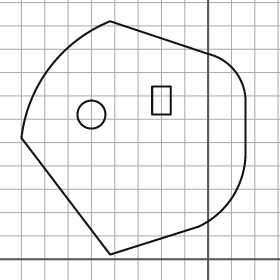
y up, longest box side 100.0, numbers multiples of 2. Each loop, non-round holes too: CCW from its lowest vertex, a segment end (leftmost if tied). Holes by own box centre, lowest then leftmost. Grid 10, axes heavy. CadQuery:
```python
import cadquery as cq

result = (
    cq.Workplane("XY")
    .moveTo(-42.0, 2.0)
    .lineTo(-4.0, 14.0)
    .threePointArc((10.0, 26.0), (16.0, 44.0))
    .lineTo(16.0, 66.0)
    .threePointArc((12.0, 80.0), (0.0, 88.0))
    .lineTo(-42.0, 102.0)
    .threePointArc((-68.0, 82.0), (-80.0, 52.0))
    .close()
    .moveTo(-50.0, 62.0)
    .circle(6.0)
    .moveTo(-24.0, 62.0)
    .lineTo(-16.0, 62.0)
    .lineTo(-16.0, 74.0)
    .lineTo(-24.0, 74.0)
    .close()
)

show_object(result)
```